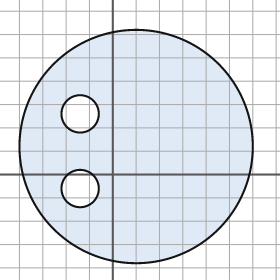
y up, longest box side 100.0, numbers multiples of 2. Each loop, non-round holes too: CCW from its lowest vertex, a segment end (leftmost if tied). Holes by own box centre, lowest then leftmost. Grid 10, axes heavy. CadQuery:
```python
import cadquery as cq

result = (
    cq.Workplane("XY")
    .moveTo(10.0, 12.0)
    .circle(50.0)
    .moveTo(-14.0, -6.0)
    .circle(8.0)
    .moveTo(-14.0, 26.0)
    .circle(8.0)
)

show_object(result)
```